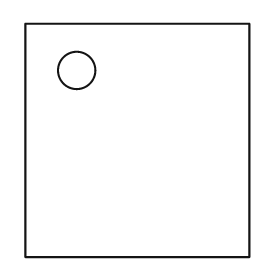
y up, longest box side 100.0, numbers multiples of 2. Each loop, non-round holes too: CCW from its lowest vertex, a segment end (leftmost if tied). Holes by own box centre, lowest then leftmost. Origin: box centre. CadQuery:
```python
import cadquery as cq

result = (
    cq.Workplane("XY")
    .moveTo(-48.0, -50.0)
    .lineTo(48.0, -50.0)
    .lineTo(48.0, 50.0)
    .lineTo(-48.0, 50.0)
    .close()
    .moveTo(-26.0, 30.0)
    .circle(8.0)
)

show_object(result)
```